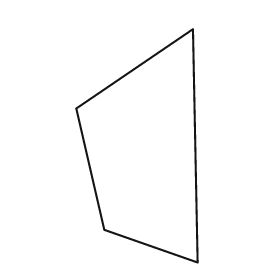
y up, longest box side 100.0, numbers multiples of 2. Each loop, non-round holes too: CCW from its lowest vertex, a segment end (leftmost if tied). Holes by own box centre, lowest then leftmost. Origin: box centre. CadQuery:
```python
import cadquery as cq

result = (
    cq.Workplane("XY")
    .moveTo(26.0, -50.0)
    .lineTo(24.0, 50.0)
    .lineTo(-26.0, 16.0)
    .lineTo(-14.0, -36.0)
    .close()
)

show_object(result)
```